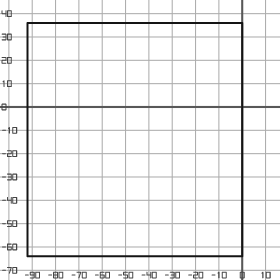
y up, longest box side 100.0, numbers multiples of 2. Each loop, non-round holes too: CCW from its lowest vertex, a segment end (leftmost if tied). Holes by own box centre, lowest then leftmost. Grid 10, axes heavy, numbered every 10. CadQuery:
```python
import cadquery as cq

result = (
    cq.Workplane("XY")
    .moveTo(-92.0, -64.0)
    .lineTo(0.0, -64.0)
    .lineTo(0.0, 36.0)
    .lineTo(-92.0, 36.0)
    .close()
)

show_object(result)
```